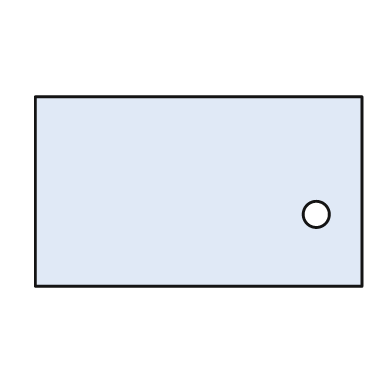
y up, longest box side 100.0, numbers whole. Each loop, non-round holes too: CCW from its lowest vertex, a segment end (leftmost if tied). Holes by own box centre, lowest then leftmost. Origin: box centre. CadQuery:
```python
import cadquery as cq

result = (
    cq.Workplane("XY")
    .moveTo(-50.0, -29.0)
    .lineTo(50.0, -29.0)
    .lineTo(50.0, 29.0)
    .lineTo(-50.0, 29.0)
    .close()
    .moveTo(36.0, -7.0)
    .circle(4.0)
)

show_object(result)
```